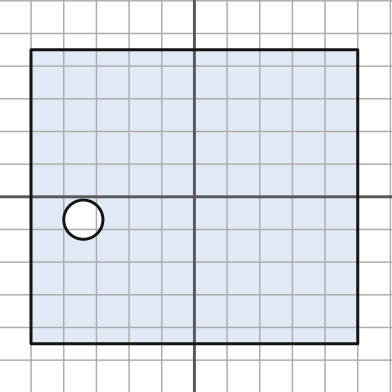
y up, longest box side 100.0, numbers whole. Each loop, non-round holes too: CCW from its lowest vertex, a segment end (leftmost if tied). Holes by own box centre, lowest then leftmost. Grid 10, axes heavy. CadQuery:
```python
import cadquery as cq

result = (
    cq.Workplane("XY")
    .moveTo(-50.0, -45.0)
    .lineTo(50.0, -45.0)
    .lineTo(50.0, 45.0)
    .lineTo(-50.0, 45.0)
    .close()
    .moveTo(-34.0, -7.0)
    .circle(6.0)
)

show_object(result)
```